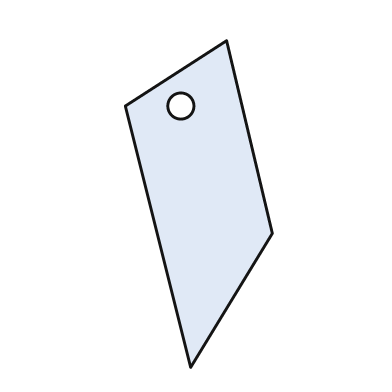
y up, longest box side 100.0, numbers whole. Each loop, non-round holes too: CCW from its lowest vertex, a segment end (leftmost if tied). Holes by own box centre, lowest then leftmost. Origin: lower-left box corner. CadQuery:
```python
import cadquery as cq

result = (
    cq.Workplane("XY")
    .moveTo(20.0, 0.0)
    .lineTo(45.0, 41.0)
    .lineTo(31.0, 100.0)
    .lineTo(0.0, 80.0)
    .close()
    .moveTo(17.0, 80.0)
    .circle(4.0)
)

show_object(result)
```